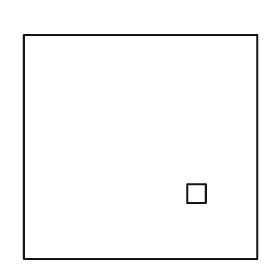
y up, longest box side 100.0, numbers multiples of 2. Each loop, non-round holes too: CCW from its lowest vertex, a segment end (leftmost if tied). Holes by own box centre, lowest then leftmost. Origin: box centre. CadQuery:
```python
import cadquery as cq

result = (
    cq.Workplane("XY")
    .moveTo(-50.0, -48.0)
    .lineTo(50.0, -48.0)
    .lineTo(50.0, 48.0)
    .lineTo(-50.0, 48.0)
    .close()
    .moveTo(20.0, -24.0)
    .lineTo(28.0, -24.0)
    .lineTo(28.0, -16.0)
    .lineTo(20.0, -16.0)
    .close()
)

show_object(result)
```